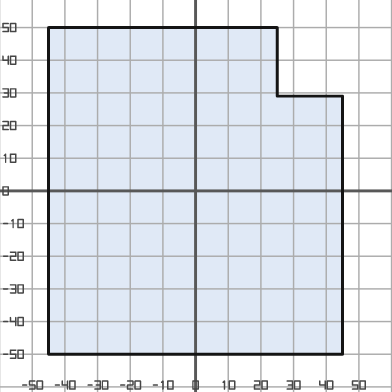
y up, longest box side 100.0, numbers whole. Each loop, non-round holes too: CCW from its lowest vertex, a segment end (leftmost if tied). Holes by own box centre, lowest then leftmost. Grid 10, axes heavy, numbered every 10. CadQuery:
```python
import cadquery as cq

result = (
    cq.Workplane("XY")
    .moveTo(-45.0, -50.0)
    .lineTo(45.0, -50.0)
    .lineTo(45.0, 29.0)
    .lineTo(25.0, 29.0)
    .lineTo(25.0, 50.0)
    .lineTo(-45.0, 50.0)
    .close()
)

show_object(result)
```